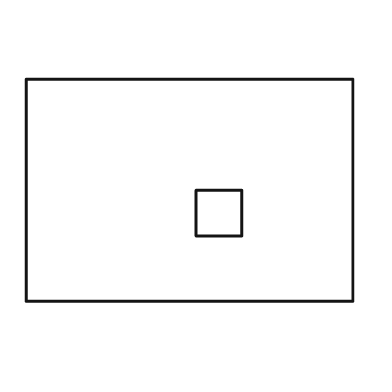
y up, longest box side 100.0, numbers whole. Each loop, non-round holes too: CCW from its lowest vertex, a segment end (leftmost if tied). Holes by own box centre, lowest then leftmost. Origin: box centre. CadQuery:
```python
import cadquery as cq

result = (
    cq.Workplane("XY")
    .moveTo(-50.0, -34.0)
    .lineTo(50.0, -34.0)
    .lineTo(50.0, 34.0)
    .lineTo(-50.0, 34.0)
    .close()
    .moveTo(2.0, -14.0)
    .lineTo(16.0, -14.0)
    .lineTo(16.0, 0.0)
    .lineTo(2.0, 0.0)
    .close()
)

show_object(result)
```